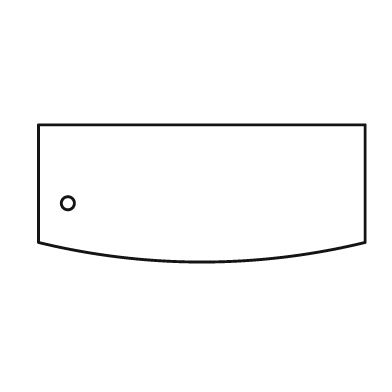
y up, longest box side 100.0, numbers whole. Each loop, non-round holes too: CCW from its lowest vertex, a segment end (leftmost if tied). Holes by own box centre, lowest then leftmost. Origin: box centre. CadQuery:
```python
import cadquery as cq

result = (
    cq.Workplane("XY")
    .moveTo(-50.0, -15.0)
    .threePointArc((0.0, -21.0), (50.0, -15.0))
    .lineTo(50.0, 21.0)
    .lineTo(-50.0, 21.0)
    .close()
    .moveTo(-41.0, -3.0)
    .circle(2.0)
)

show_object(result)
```